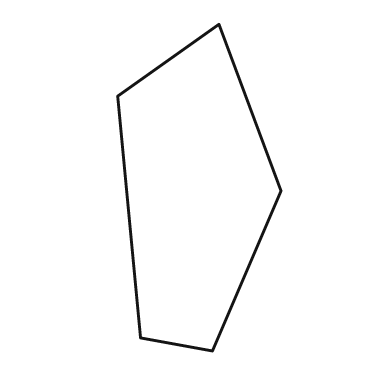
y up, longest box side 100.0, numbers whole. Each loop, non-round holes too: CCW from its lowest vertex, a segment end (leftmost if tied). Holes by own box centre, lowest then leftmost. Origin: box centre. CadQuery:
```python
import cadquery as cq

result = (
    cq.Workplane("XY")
    .moveTo(4.0, -50.0)
    .lineTo(25.0, -1.0)
    .lineTo(6.0, 50.0)
    .lineTo(-25.0, 28.0)
    .lineTo(-18.0, -46.0)
    .close()
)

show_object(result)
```